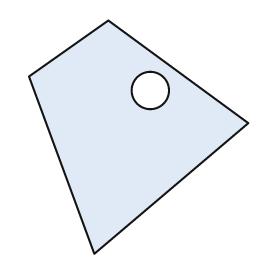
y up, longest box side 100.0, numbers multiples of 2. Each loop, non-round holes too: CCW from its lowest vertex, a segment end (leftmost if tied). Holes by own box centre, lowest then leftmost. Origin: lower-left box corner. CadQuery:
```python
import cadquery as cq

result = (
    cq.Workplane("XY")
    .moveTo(28.0, 0.0)
    .lineTo(94.0, 56.0)
    .lineTo(34.0, 100.0)
    .lineTo(0.0, 76.0)
    .close()
    .moveTo(52.0, 70.0)
    .circle(8.0)
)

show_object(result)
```